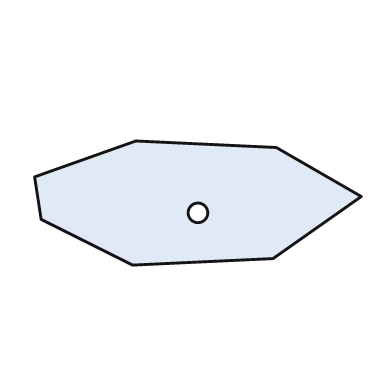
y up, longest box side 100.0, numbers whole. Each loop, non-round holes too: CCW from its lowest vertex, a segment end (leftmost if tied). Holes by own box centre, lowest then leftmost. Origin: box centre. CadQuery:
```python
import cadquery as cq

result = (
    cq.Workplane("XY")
    .moveTo(-20.0, -19.0)
    .lineTo(23.0, -17.0)
    .lineTo(50.0, 2.0)
    .lineTo(24.0, 17.0)
    .lineTo(-19.0, 19.0)
    .lineTo(-50.0, 8.0)
    .lineTo(-48.0, -5.0)
    .close()
    .moveTo(0.0, -3.0)
    .circle(3.0)
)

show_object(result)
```